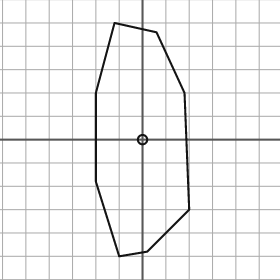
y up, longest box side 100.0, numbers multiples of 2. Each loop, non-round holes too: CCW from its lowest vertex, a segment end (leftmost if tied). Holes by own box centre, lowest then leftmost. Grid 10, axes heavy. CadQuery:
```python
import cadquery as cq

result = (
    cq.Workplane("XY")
    .moveTo(-10.0, -50.0)
    .lineTo(2.0, -48.0)
    .lineTo(20.0, -30.0)
    .lineTo(18.0, 20.0)
    .lineTo(6.0, 46.0)
    .lineTo(-12.0, 50.0)
    .lineTo(-20.0, 20.0)
    .lineTo(-20.0, -18.0)
    .close()
    .moveTo(0.0, 0.0)
    .circle(2.0)
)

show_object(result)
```